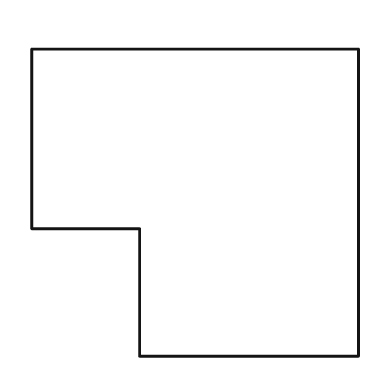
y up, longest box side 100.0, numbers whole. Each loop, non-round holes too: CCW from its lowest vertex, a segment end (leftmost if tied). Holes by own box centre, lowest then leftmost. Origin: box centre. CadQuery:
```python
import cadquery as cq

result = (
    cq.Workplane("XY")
    .moveTo(-17.0, -47.0)
    .lineTo(50.0, -47.0)
    .lineTo(50.0, 47.0)
    .lineTo(-50.0, 47.0)
    .lineTo(-50.0, -8.0)
    .lineTo(-17.0, -8.0)
    .close()
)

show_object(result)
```